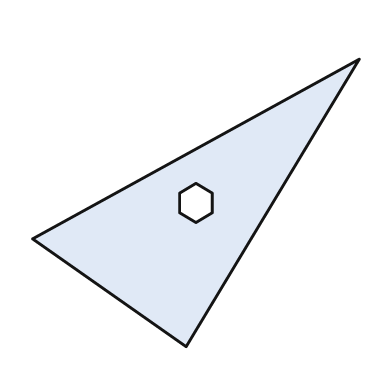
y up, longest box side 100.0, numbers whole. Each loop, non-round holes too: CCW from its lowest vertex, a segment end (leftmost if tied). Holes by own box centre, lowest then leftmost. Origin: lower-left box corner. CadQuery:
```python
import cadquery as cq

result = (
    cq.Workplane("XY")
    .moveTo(47.0, 0.0)
    .lineTo(100.0, 88.0)
    .lineTo(0.0, 33.0)
    .close()
    .moveTo(50.0, 38.0)
    .lineTo(55.0, 41.0)
    .lineTo(55.0, 47.0)
    .lineTo(50.0, 50.0)
    .lineTo(45.0, 47.0)
    .lineTo(45.0, 41.0)
    .close()
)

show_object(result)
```